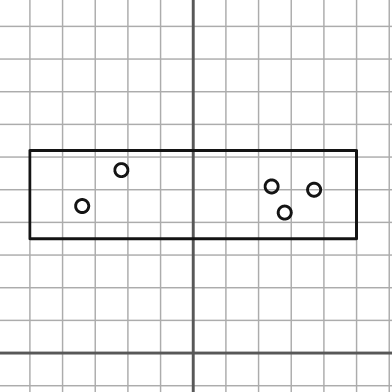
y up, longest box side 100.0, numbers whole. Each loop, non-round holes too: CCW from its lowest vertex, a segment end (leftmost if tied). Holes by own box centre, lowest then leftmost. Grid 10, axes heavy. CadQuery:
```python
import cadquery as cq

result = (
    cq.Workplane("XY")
    .moveTo(-50.0, 35.0)
    .lineTo(50.0, 35.0)
    .lineTo(50.0, 62.0)
    .lineTo(-50.0, 62.0)
    .close()
    .moveTo(28.0, 43.0)
    .circle(2.0)
    .moveTo(-34.0, 45.0)
    .circle(2.0)
    .moveTo(37.0, 50.0)
    .circle(2.0)
    .moveTo(24.0, 51.0)
    .circle(2.0)
    .moveTo(-22.0, 56.0)
    .circle(2.0)
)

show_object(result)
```